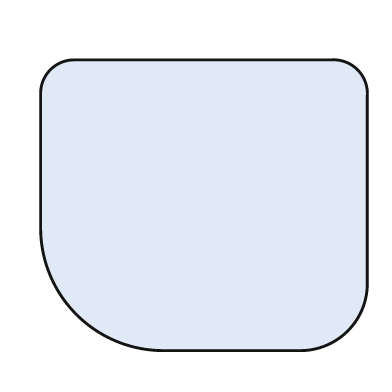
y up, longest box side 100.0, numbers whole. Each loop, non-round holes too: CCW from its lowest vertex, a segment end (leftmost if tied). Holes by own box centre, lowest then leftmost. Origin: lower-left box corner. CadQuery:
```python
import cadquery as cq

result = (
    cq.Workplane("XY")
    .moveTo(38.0, 0.0)
    .lineTo(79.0, 0.0)
    .threePointArc((94.0, 6.0), (100.0, 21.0))
    .lineTo(100.0, 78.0)
    .threePointArc((97.0, 86.0), (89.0, 89.0))
    .lineTo(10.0, 89.0)
    .threePointArc((3.0, 86.0), (0.0, 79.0))
    .lineTo(0.0, 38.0)
    .threePointArc((11.0, 11.0), (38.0, 0.0))
    .close()
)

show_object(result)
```